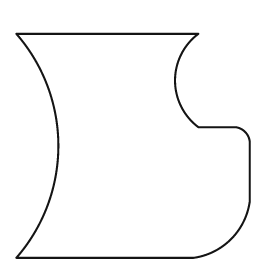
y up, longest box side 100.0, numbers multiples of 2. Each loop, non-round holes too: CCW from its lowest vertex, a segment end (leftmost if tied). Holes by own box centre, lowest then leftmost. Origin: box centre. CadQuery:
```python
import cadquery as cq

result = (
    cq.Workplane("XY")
    .moveTo(-50.0, -48.0)
    .lineTo(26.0, -48.0)
    .threePointArc((42.0, -40.0), (50.0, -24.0))
    .lineTo(50.0, 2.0)
    .threePointArc((48.0, 6.0), (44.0, 8.0))
    .lineTo(28.0, 8.0)
    .threePointArc((18.0, 28.0), (28.0, 48.0))
    .lineTo(-50.0, 48.0)
    .threePointArc((-32.0, 0.0), (-50.0, -48.0))
    .close()
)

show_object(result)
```